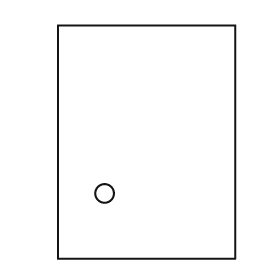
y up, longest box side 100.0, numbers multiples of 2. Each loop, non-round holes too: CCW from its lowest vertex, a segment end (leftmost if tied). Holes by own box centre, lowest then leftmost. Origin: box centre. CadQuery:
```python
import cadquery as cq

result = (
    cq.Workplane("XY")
    .moveTo(-38.0, -50.0)
    .lineTo(38.0, -50.0)
    .lineTo(38.0, 50.0)
    .lineTo(-38.0, 50.0)
    .close()
    .moveTo(-18.0, -22.0)
    .circle(4.0)
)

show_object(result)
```